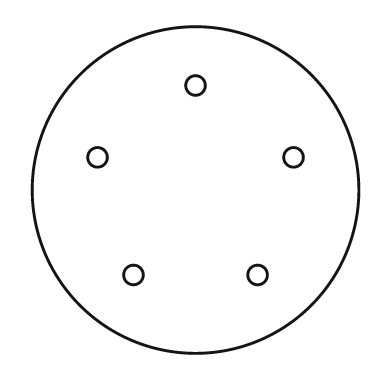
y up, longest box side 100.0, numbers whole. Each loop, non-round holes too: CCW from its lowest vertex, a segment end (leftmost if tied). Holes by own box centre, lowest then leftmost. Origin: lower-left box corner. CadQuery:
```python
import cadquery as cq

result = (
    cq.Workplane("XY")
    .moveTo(50.0, 50.0)
    .circle(50.0)
    .moveTo(31.0, 24.0)
    .circle(3.0)
    .moveTo(69.0, 24.0)
    .circle(3.0)
    .moveTo(20.0, 60.0)
    .circle(3.0)
    .moveTo(80.0, 60.0)
    .circle(3.0)
    .moveTo(50.0, 82.0)
    .circle(3.0)
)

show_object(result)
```